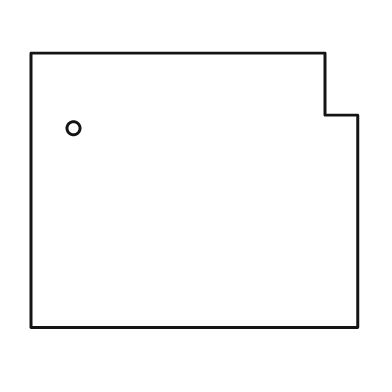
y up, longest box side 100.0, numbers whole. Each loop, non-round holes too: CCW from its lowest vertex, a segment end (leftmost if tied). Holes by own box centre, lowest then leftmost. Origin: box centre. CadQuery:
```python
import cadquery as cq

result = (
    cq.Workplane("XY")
    .moveTo(-50.0, -42.0)
    .lineTo(50.0, -42.0)
    .lineTo(50.0, 23.0)
    .lineTo(40.0, 23.0)
    .lineTo(40.0, 42.0)
    .lineTo(-50.0, 42.0)
    .close()
    .moveTo(-37.0, 19.0)
    .circle(2.0)
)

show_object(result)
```